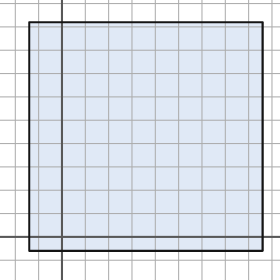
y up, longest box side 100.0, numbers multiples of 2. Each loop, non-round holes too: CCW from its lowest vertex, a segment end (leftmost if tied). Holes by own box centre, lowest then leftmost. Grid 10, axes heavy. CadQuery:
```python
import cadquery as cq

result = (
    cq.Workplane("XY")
    .moveTo(-14.0, -6.0)
    .lineTo(86.0, -6.0)
    .lineTo(86.0, 92.0)
    .lineTo(-14.0, 92.0)
    .close()
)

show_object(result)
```